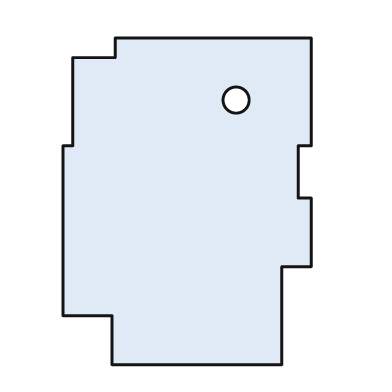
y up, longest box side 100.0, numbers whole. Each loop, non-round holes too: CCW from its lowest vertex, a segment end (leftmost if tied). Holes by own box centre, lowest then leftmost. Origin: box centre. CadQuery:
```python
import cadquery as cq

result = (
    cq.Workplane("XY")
    .moveTo(-23.0, -50.0)
    .lineTo(29.0, -50.0)
    .lineTo(29.0, -20.0)
    .lineTo(38.0, -20.0)
    .lineTo(38.0, 1.0)
    .lineTo(34.0, 1.0)
    .lineTo(34.0, 17.0)
    .lineTo(38.0, 17.0)
    .lineTo(38.0, 50.0)
    .lineTo(-22.0, 50.0)
    .lineTo(-22.0, 44.0)
    .lineTo(-35.0, 44.0)
    .lineTo(-35.0, 17.0)
    .lineTo(-38.0, 17.0)
    .lineTo(-38.0, -35.0)
    .lineTo(-23.0, -35.0)
    .close()
    .moveTo(15.0, 31.0)
    .circle(4.0)
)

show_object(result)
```